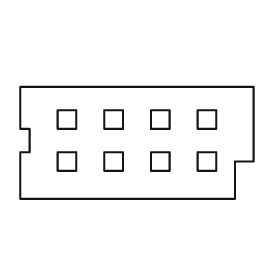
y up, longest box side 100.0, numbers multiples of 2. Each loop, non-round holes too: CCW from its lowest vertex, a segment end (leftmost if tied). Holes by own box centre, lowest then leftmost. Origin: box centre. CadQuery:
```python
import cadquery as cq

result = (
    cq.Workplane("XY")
    .moveTo(-50.0, -24.0)
    .lineTo(42.0, -24.0)
    .lineTo(42.0, -8.0)
    .lineTo(50.0, -8.0)
    .lineTo(50.0, 24.0)
    .lineTo(-50.0, 24.0)
    .lineTo(-50.0, 6.0)
    .lineTo(-46.0, 6.0)
    .lineTo(-46.0, -4.0)
    .lineTo(-50.0, -4.0)
    .close()
    .moveTo(-34.0, -12.0)
    .lineTo(-26.0, -12.0)
    .lineTo(-26.0, -4.0)
    .lineTo(-34.0, -4.0)
    .close()
    .moveTo(-14.0, -12.0)
    .lineTo(-6.0, -12.0)
    .lineTo(-6.0, -4.0)
    .lineTo(-14.0, -4.0)
    .close()
    .moveTo(6.0, -12.0)
    .lineTo(14.0, -12.0)
    .lineTo(14.0, -4.0)
    .lineTo(6.0, -4.0)
    .close()
    .moveTo(26.0, -12.0)
    .lineTo(34.0, -12.0)
    .lineTo(34.0, -4.0)
    .lineTo(26.0, -4.0)
    .close()
    .moveTo(-34.0, 6.0)
    .lineTo(-26.0, 6.0)
    .lineTo(-26.0, 14.0)
    .lineTo(-34.0, 14.0)
    .close()
    .moveTo(-14.0, 6.0)
    .lineTo(-6.0, 6.0)
    .lineTo(-6.0, 14.0)
    .lineTo(-14.0, 14.0)
    .close()
    .moveTo(6.0, 6.0)
    .lineTo(14.0, 6.0)
    .lineTo(14.0, 14.0)
    .lineTo(6.0, 14.0)
    .close()
    .moveTo(26.0, 6.0)
    .lineTo(34.0, 6.0)
    .lineTo(34.0, 14.0)
    .lineTo(26.0, 14.0)
    .close()
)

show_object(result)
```